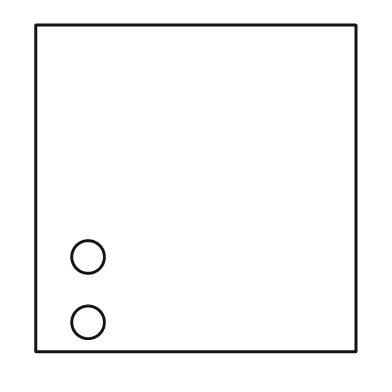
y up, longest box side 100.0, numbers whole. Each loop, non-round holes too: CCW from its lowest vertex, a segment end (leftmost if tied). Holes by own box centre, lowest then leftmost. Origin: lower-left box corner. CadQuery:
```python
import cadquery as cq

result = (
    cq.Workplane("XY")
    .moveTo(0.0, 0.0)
    .lineTo(98.0, 0.0)
    .lineTo(98.0, 100.0)
    .lineTo(0.0, 100.0)
    .close()
    .moveTo(16.0, 9.0)
    .circle(5.0)
    .moveTo(16.0, 29.0)
    .circle(5.0)
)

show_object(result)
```